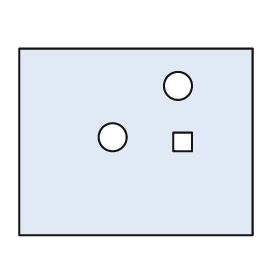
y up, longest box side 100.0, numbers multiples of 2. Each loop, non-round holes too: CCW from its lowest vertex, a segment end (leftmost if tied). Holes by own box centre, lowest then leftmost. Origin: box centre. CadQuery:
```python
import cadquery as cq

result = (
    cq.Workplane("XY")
    .moveTo(-50.0, -40.0)
    .lineTo(50.0, -40.0)
    .lineTo(50.0, 40.0)
    .lineTo(-50.0, 40.0)
    .close()
    .moveTo(16.0, -4.0)
    .lineTo(24.0, -4.0)
    .lineTo(24.0, 4.0)
    .lineTo(16.0, 4.0)
    .close()
    .moveTo(-10.0, 2.0)
    .circle(6.0)
    .moveTo(18.0, 24.0)
    .circle(6.0)
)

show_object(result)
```